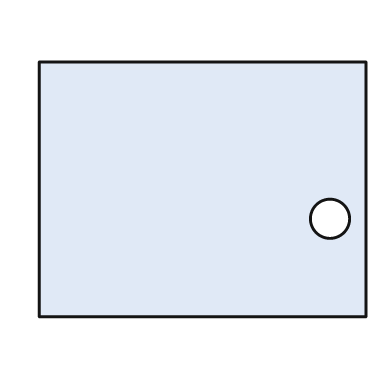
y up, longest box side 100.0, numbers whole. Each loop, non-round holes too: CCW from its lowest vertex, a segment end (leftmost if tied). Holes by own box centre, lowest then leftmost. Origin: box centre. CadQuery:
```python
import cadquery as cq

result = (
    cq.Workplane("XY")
    .moveTo(-50.0, -39.0)
    .lineTo(50.0, -39.0)
    .lineTo(50.0, 39.0)
    .lineTo(-50.0, 39.0)
    .close()
    .moveTo(39.0, -9.0)
    .circle(6.0)
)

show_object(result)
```